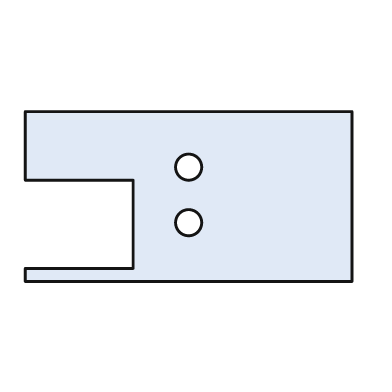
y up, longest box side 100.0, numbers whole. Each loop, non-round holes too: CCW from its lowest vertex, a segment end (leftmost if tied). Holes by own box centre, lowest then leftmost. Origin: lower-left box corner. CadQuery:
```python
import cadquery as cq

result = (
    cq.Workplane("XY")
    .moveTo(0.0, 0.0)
    .lineTo(100.0, 0.0)
    .lineTo(100.0, 52.0)
    .lineTo(0.0, 52.0)
    .lineTo(0.0, 31.0)
    .lineTo(33.0, 31.0)
    .lineTo(33.0, 4.0)
    .lineTo(0.0, 4.0)
    .close()
    .moveTo(50.0, 18.0)
    .circle(4.0)
    .moveTo(50.0, 35.0)
    .circle(4.0)
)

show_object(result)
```